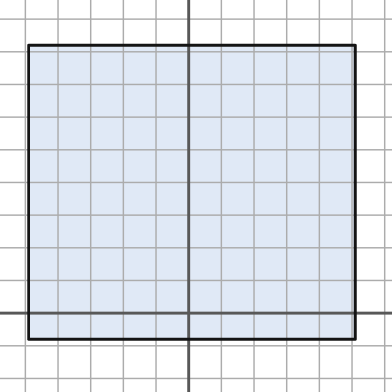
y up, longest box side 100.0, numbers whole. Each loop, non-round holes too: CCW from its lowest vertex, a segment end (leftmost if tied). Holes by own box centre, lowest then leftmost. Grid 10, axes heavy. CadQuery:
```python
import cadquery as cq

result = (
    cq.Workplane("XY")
    .moveTo(-49.0, -8.0)
    .lineTo(51.0, -8.0)
    .lineTo(51.0, 82.0)
    .lineTo(-49.0, 82.0)
    .close()
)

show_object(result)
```